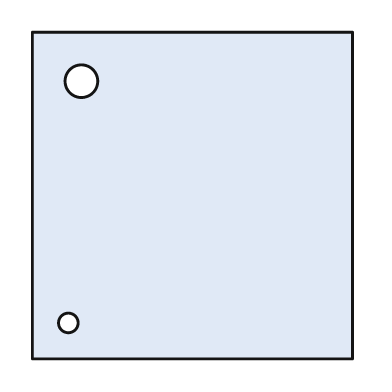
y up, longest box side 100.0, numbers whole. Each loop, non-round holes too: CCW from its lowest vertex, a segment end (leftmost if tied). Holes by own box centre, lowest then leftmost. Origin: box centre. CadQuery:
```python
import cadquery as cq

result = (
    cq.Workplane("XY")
    .moveTo(-49.0, -50.0)
    .lineTo(49.0, -50.0)
    .lineTo(49.0, 50.0)
    .lineTo(-49.0, 50.0)
    .close()
    .moveTo(-38.0, -39.0)
    .circle(3.0)
    .moveTo(-34.0, 35.0)
    .circle(5.0)
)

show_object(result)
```